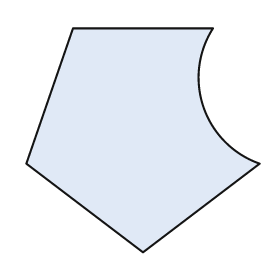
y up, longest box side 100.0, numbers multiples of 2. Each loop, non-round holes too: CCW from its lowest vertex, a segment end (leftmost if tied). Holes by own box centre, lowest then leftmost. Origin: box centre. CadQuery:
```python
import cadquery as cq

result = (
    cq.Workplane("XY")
    .moveTo(0.0, -48.0)
    .lineTo(50.0, -10.0)
    .threePointArc((26.0, 14.0), (30.0, 48.0))
    .lineTo(-30.0, 48.0)
    .lineTo(-50.0, -10.0)
    .close()
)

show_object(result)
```